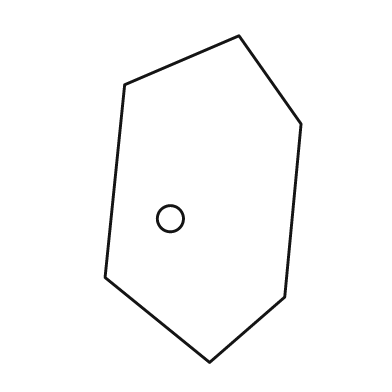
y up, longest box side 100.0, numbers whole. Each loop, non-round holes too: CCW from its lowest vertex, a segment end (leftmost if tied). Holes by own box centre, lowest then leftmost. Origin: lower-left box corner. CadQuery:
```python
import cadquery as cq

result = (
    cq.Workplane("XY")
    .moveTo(32.0, 0.0)
    .lineTo(55.0, 20.0)
    .lineTo(60.0, 73.0)
    .lineTo(41.0, 100.0)
    .lineTo(6.0, 85.0)
    .lineTo(0.0, 26.0)
    .close()
    .moveTo(20.0, 44.0)
    .circle(4.0)
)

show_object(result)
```